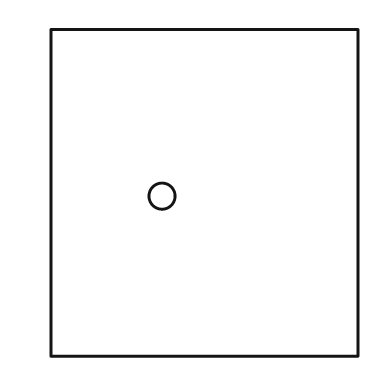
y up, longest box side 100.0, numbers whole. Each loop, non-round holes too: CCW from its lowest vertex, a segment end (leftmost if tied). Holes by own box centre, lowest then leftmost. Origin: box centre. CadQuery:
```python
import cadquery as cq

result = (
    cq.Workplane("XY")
    .moveTo(-47.0, -50.0)
    .lineTo(47.0, -50.0)
    .lineTo(47.0, 50.0)
    .lineTo(-47.0, 50.0)
    .close()
    .moveTo(-13.0, -1.0)
    .circle(4.0)
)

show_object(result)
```